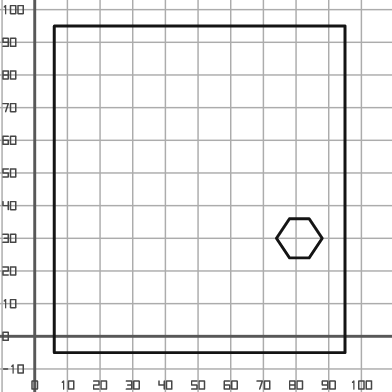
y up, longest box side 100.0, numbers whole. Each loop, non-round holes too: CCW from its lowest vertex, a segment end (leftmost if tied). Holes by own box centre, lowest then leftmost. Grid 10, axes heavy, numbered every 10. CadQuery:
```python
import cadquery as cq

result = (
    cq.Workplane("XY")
    .moveTo(6.0, -5.0)
    .lineTo(95.0, -5.0)
    .lineTo(95.0, 95.0)
    .lineTo(6.0, 95.0)
    .close()
    .moveTo(78.0, 24.0)
    .lineTo(84.0, 24.0)
    .lineTo(88.0, 30.0)
    .lineTo(84.0, 36.0)
    .lineTo(78.0, 36.0)
    .lineTo(74.0, 30.0)
    .close()
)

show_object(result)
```